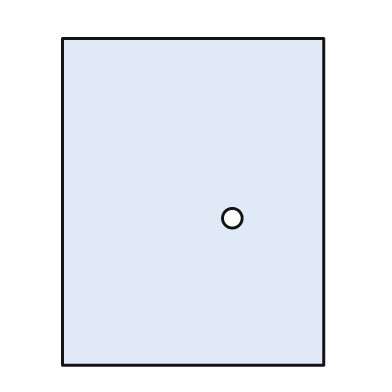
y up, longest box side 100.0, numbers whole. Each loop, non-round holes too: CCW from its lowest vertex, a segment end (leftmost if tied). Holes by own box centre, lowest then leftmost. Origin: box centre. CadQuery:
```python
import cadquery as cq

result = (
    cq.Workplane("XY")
    .moveTo(-40.0, -50.0)
    .lineTo(40.0, -50.0)
    .lineTo(40.0, 50.0)
    .lineTo(-40.0, 50.0)
    .close()
    .moveTo(12.0, -5.0)
    .circle(3.0)
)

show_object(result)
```